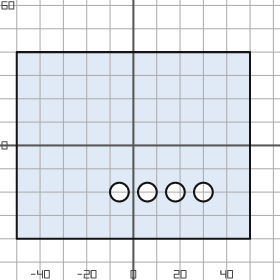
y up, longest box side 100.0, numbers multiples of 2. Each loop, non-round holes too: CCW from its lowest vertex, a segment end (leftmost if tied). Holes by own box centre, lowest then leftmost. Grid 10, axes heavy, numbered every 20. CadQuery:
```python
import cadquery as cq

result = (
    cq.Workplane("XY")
    .moveTo(-50.0, -40.0)
    .lineTo(50.0, -40.0)
    .lineTo(50.0, 40.0)
    .lineTo(-50.0, 40.0)
    .close()
    .moveTo(-6.0, -20.0)
    .circle(4.0)
    .moveTo(6.0, -20.0)
    .circle(4.0)
    .moveTo(18.0, -20.0)
    .circle(4.0)
    .moveTo(30.0, -20.0)
    .circle(4.0)
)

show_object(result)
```